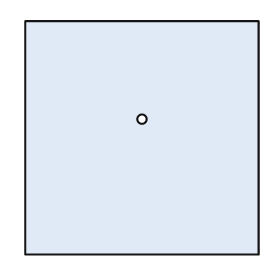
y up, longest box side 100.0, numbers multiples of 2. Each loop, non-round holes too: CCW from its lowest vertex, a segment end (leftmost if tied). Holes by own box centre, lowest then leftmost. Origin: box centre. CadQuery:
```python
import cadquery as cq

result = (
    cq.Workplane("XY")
    .moveTo(-50.0, -50.0)
    .lineTo(50.0, -50.0)
    .lineTo(50.0, 50.0)
    .lineTo(-50.0, 50.0)
    .close()
    .moveTo(0.0, 8.0)
    .circle(2.0)
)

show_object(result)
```